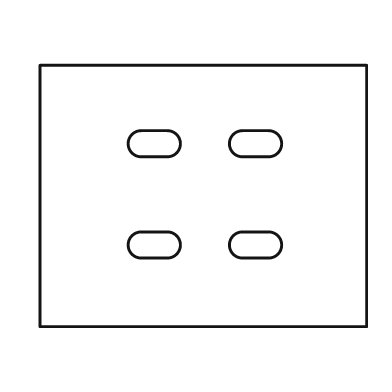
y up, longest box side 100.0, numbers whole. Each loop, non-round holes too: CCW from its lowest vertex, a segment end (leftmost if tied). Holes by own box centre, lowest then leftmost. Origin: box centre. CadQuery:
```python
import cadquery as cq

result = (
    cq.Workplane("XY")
    .moveTo(-50.0, -40.0)
    .lineTo(50.0, -40.0)
    .lineTo(50.0, 40.0)
    .lineTo(-50.0, 40.0)
    .close()
    .moveTo(-19.0, -19.0)
    .lineTo(-11.0, -19.0)
    .threePointArc((-7.0, -15.0), (-11.0, -11.0))
    .lineTo(-19.0, -11.0)
    .threePointArc((-23.0, -15.0), (-19.0, -19.0))
    .close()
    .moveTo(12.0, -19.0)
    .lineTo(20.0, -19.0)
    .threePointArc((24.0, -15.0), (20.0, -11.0))
    .lineTo(12.0, -11.0)
    .threePointArc((8.0, -15.0), (12.0, -19.0))
    .close()
    .moveTo(-19.0, 12.0)
    .lineTo(-11.0, 12.0)
    .threePointArc((-7.0, 16.0), (-11.0, 20.0))
    .lineTo(-19.0, 20.0)
    .threePointArc((-23.0, 16.0), (-19.0, 12.0))
    .close()
    .moveTo(12.0, 12.0)
    .lineTo(20.0, 12.0)
    .threePointArc((24.0, 16.0), (20.0, 20.0))
    .lineTo(12.0, 20.0)
    .threePointArc((8.0, 16.0), (12.0, 12.0))
    .close()
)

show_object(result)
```